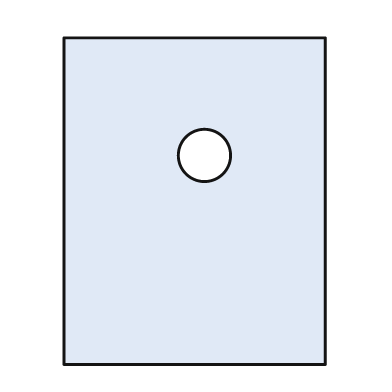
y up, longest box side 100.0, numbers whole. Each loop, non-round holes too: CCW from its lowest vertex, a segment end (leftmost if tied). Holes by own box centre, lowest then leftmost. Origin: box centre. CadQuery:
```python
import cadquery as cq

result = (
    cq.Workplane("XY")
    .moveTo(-40.0, -50.0)
    .lineTo(40.0, -50.0)
    .lineTo(40.0, 50.0)
    .lineTo(-40.0, 50.0)
    .close()
    .moveTo(3.0, 14.0)
    .circle(8.0)
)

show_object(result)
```